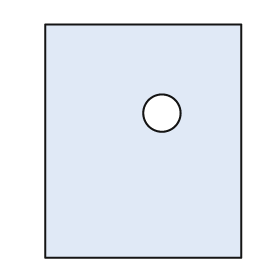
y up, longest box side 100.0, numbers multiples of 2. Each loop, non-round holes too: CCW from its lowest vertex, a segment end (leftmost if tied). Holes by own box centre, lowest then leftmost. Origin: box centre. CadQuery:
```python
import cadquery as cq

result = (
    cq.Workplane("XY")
    .moveTo(-42.0, -50.0)
    .lineTo(42.0, -50.0)
    .lineTo(42.0, 50.0)
    .lineTo(-42.0, 50.0)
    .close()
    .moveTo(8.0, 12.0)
    .circle(8.0)
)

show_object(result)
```